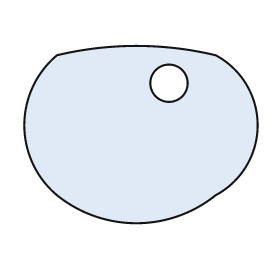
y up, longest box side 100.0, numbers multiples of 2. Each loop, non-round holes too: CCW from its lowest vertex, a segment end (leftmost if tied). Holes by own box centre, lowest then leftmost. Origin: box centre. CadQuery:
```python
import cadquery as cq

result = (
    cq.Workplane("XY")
    .moveTo(-36.0, -26.0)
    .threePointArc((-2.0, -38.0), (32.0, -26.0))
    .threePointArc((50.0, 4.0), (32.0, 34.0))
    .threePointArc((-2.0, 38.0), (-36.0, 34.0))
    .threePointArc((-50.0, 4.0), (-36.0, -26.0))
    .close()
    .moveTo(12.0, 22.0)
    .circle(8.0)
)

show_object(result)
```